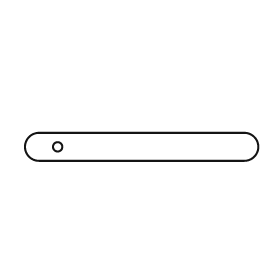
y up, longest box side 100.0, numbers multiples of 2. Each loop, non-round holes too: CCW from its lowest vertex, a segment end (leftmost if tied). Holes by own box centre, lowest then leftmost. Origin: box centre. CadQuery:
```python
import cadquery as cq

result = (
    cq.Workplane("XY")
    .moveTo(-44.0, -6.0)
    .lineTo(44.0, -6.0)
    .threePointArc((50.0, 0.0), (44.0, 6.0))
    .lineTo(-44.0, 6.0)
    .threePointArc((-50.0, 0.0), (-44.0, -6.0))
    .close()
    .moveTo(-36.0, 0.0)
    .circle(2.0)
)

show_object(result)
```